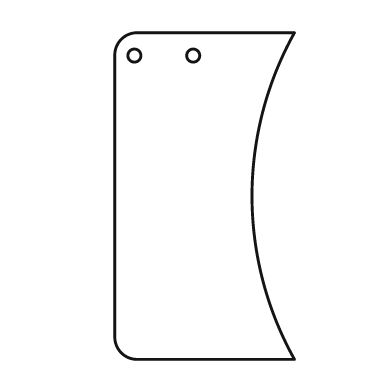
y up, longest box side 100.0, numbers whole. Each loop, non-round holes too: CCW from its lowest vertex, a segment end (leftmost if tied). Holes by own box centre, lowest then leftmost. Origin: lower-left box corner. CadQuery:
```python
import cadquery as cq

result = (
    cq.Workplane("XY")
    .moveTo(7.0, 0.0)
    .lineTo(55.0, 0.0)
    .threePointArc((42.0, 50.0), (55.0, 100.0))
    .lineTo(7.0, 100.0)
    .threePointArc((2.0, 98.0), (0.0, 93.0))
    .lineTo(0.0, 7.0)
    .threePointArc((2.0, 2.0), (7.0, 0.0))
    .close()
    .moveTo(6.0, 93.0)
    .circle(2.0)
    .moveTo(24.0, 93.0)
    .circle(2.0)
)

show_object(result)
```